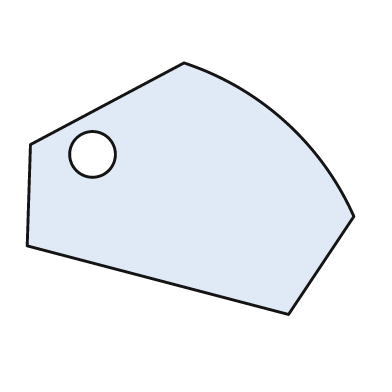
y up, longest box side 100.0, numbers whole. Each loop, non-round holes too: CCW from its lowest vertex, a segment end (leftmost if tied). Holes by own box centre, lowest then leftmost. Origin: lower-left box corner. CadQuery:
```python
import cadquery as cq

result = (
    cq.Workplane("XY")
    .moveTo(80.0, 0.0)
    .lineTo(100.0, 30.0)
    .threePointArc((79.0, 59.0), (48.0, 77.0))
    .lineTo(1.0, 52.0)
    .lineTo(0.0, 21.0)
    .close()
    .moveTo(20.0, 49.0)
    .circle(7.0)
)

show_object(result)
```